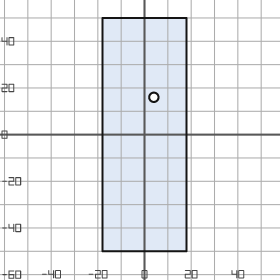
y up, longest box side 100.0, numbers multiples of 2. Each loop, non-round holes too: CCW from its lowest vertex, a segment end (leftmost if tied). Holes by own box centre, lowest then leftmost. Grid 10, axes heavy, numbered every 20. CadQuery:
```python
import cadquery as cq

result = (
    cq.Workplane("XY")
    .moveTo(-18.0, -50.0)
    .lineTo(18.0, -50.0)
    .lineTo(18.0, 50.0)
    .lineTo(-18.0, 50.0)
    .close()
    .moveTo(4.0, 16.0)
    .circle(2.0)
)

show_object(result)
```